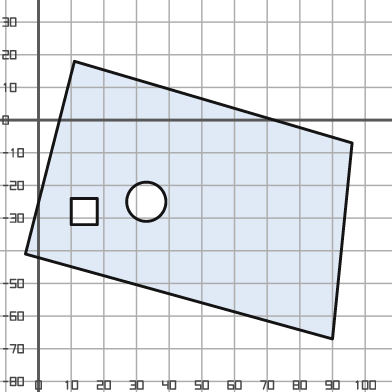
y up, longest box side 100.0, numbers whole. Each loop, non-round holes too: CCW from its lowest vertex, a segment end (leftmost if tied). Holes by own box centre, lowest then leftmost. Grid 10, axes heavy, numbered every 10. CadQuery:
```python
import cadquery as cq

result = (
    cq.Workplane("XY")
    .moveTo(90.0, -67.0)
    .lineTo(96.0, -7.0)
    .lineTo(11.0, 18.0)
    .lineTo(-4.0, -41.0)
    .close()
    .moveTo(10.0, -32.0)
    .lineTo(18.0, -32.0)
    .lineTo(18.0, -24.0)
    .lineTo(10.0, -24.0)
    .close()
    .moveTo(33.0, -25.0)
    .circle(6.0)
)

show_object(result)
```